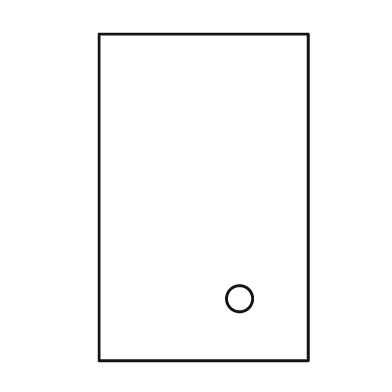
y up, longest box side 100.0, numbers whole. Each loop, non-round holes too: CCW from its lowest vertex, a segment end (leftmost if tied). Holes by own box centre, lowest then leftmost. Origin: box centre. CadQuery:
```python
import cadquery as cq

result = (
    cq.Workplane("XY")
    .moveTo(-32.0, -50.0)
    .lineTo(32.0, -50.0)
    .lineTo(32.0, 50.0)
    .lineTo(-32.0, 50.0)
    .close()
    .moveTo(11.0, -31.0)
    .circle(4.0)
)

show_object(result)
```